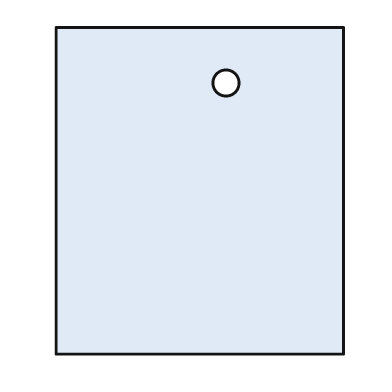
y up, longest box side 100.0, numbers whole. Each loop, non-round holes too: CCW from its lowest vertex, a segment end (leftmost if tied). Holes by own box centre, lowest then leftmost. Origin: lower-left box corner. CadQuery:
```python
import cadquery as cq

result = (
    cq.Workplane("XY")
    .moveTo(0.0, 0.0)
    .lineTo(88.0, 0.0)
    .lineTo(88.0, 100.0)
    .lineTo(0.0, 100.0)
    .close()
    .moveTo(52.0, 83.0)
    .circle(4.0)
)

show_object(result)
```